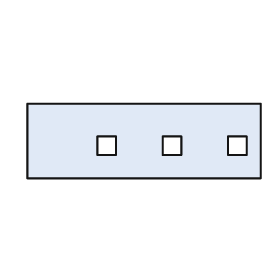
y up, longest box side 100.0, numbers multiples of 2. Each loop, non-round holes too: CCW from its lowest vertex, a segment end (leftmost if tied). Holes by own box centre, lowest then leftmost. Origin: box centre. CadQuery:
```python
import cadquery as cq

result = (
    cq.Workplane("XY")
    .moveTo(-50.0, -16.0)
    .lineTo(50.0, -16.0)
    .lineTo(50.0, 16.0)
    .lineTo(-50.0, 16.0)
    .close()
    .moveTo(-20.0, -6.0)
    .lineTo(-12.0, -6.0)
    .lineTo(-12.0, 2.0)
    .lineTo(-20.0, 2.0)
    .close()
    .moveTo(8.0, -6.0)
    .lineTo(16.0, -6.0)
    .lineTo(16.0, 2.0)
    .lineTo(8.0, 2.0)
    .close()
    .moveTo(36.0, -6.0)
    .lineTo(44.0, -6.0)
    .lineTo(44.0, 2.0)
    .lineTo(36.0, 2.0)
    .close()
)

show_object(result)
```